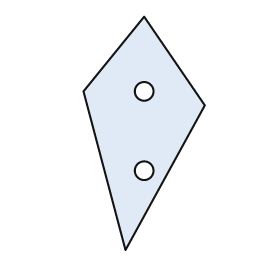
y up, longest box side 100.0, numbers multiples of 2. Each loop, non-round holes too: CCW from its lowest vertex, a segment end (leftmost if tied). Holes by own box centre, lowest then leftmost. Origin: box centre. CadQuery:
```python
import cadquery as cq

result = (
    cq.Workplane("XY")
    .moveTo(-8.0, -50.0)
    .lineTo(26.0, 12.0)
    .lineTo(0.0, 50.0)
    .lineTo(-26.0, 18.0)
    .close()
    .moveTo(0.0, -16.0)
    .circle(4.0)
    .moveTo(0.0, 18.0)
    .circle(4.0)
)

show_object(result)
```